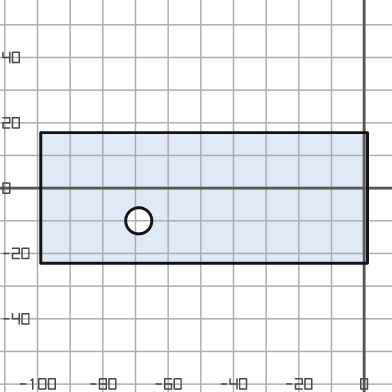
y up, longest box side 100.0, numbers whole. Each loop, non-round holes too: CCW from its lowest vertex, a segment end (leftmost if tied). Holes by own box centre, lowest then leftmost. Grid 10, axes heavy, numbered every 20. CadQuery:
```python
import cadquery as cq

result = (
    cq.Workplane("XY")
    .moveTo(-99.0, -23.0)
    .lineTo(1.0, -23.0)
    .lineTo(1.0, 17.0)
    .lineTo(-99.0, 17.0)
    .close()
    .moveTo(-69.0, -10.0)
    .circle(4.0)
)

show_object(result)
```